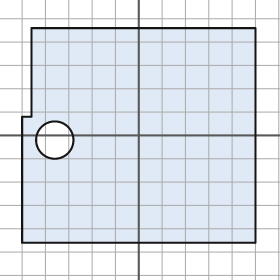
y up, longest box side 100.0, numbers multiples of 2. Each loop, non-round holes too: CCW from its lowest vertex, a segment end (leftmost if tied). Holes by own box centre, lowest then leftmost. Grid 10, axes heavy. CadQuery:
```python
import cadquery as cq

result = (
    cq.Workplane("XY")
    .moveTo(-50.0, -46.0)
    .lineTo(50.0, -46.0)
    .lineTo(50.0, 46.0)
    .lineTo(-46.0, 46.0)
    .lineTo(-46.0, 8.0)
    .lineTo(-50.0, 8.0)
    .close()
    .moveTo(-36.0, -2.0)
    .circle(8.0)
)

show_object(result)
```